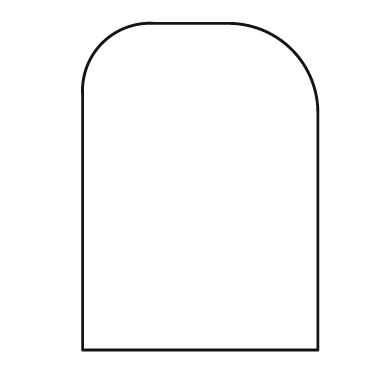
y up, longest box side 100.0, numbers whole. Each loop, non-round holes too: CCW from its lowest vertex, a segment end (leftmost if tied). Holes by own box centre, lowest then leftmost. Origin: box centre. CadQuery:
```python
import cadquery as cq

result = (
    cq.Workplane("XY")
    .moveTo(-36.0, -50.0)
    .lineTo(36.0, -50.0)
    .lineTo(36.0, 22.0)
    .threePointArc((28.0, 42.0), (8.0, 50.0))
    .lineTo(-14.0, 50.0)
    .threePointArc((-30.0, 44.0), (-36.0, 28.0))
    .close()
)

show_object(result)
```